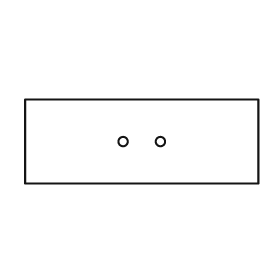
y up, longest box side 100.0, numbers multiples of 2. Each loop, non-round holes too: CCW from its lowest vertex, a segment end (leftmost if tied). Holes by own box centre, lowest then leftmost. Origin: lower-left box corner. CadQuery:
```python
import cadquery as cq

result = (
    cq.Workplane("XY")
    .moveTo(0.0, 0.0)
    .lineTo(100.0, 0.0)
    .lineTo(100.0, 36.0)
    .lineTo(0.0, 36.0)
    .close()
    .moveTo(42.0, 18.0)
    .circle(2.0)
    .moveTo(58.0, 18.0)
    .circle(2.0)
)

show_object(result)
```